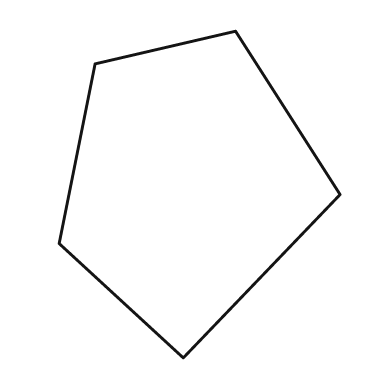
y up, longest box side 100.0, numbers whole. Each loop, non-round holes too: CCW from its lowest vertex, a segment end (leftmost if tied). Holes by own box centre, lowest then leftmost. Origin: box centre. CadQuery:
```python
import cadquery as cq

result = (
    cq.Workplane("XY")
    .moveTo(-5.0, -50.0)
    .lineTo(43.0, 0.0)
    .lineTo(11.0, 50.0)
    .lineTo(-32.0, 40.0)
    .lineTo(-43.0, -15.0)
    .close()
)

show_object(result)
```